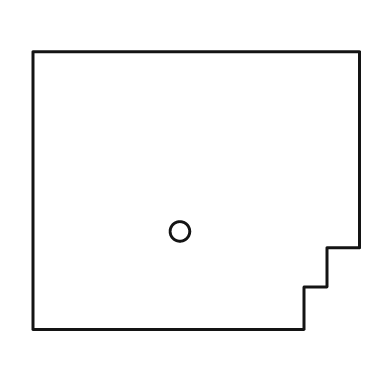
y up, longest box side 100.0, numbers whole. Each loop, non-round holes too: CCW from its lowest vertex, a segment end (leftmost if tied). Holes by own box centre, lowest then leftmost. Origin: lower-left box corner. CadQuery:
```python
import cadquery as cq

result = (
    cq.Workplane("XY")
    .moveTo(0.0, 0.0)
    .lineTo(83.0, 0.0)
    .lineTo(83.0, 13.0)
    .lineTo(90.0, 13.0)
    .lineTo(90.0, 25.0)
    .lineTo(100.0, 25.0)
    .lineTo(100.0, 85.0)
    .lineTo(0.0, 85.0)
    .close()
    .moveTo(45.0, 30.0)
    .circle(3.0)
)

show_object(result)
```